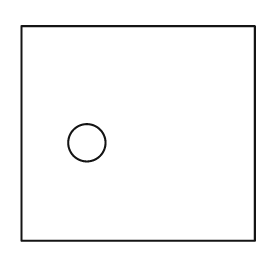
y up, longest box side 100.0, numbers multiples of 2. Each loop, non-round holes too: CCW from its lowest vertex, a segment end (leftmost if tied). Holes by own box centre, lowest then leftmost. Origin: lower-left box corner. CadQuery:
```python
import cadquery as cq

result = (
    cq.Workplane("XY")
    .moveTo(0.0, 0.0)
    .lineTo(100.0, 0.0)
    .lineTo(100.0, 92.0)
    .lineTo(0.0, 92.0)
    .close()
    .moveTo(28.0, 42.0)
    .circle(8.0)
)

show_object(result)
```